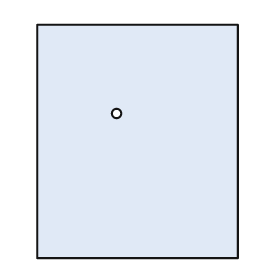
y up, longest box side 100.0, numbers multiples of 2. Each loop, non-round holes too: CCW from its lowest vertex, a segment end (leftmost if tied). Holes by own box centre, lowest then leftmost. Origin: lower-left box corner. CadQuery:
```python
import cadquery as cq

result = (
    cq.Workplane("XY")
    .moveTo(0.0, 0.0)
    .lineTo(86.0, 0.0)
    .lineTo(86.0, 100.0)
    .lineTo(0.0, 100.0)
    .close()
    .moveTo(34.0, 62.0)
    .circle(2.0)
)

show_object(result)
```